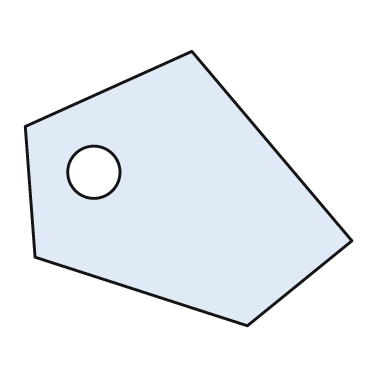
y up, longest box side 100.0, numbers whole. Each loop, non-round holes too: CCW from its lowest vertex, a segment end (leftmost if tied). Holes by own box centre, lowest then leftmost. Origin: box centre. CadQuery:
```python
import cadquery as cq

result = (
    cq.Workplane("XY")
    .moveTo(18.0, -42.0)
    .lineTo(50.0, -16.0)
    .lineTo(1.0, 42.0)
    .lineTo(-50.0, 19.0)
    .lineTo(-47.0, -21.0)
    .close()
    .moveTo(-29.0, 5.0)
    .circle(8.0)
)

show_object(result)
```